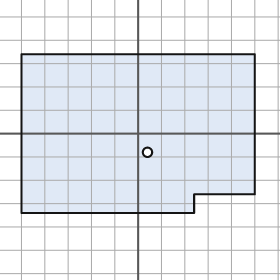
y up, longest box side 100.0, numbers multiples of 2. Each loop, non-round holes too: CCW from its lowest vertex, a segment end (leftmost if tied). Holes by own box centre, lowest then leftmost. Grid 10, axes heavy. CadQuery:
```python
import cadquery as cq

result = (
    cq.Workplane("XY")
    .moveTo(-50.0, -34.0)
    .lineTo(24.0, -34.0)
    .lineTo(24.0, -26.0)
    .lineTo(50.0, -26.0)
    .lineTo(50.0, 34.0)
    .lineTo(-50.0, 34.0)
    .close()
    .moveTo(4.0, -8.0)
    .circle(2.0)
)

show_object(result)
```